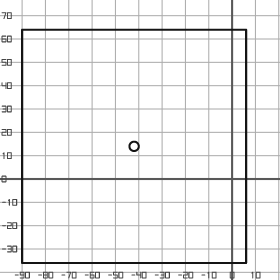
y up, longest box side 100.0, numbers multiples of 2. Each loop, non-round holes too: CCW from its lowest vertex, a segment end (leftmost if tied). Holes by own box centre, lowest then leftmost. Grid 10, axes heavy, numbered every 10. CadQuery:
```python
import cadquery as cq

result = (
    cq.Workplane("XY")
    .moveTo(-90.0, -36.0)
    .lineTo(6.0, -36.0)
    .lineTo(6.0, 64.0)
    .lineTo(-90.0, 64.0)
    .close()
    .moveTo(-42.0, 14.0)
    .circle(2.0)
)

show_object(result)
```